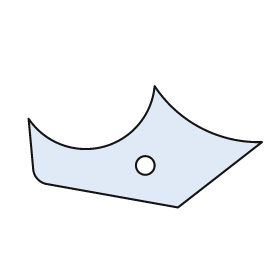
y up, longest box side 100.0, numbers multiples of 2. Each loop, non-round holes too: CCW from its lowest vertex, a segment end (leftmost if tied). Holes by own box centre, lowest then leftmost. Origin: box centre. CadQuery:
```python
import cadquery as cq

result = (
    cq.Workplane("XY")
    .moveTo(14.0, -26.0)
    .lineTo(50.0, 2.0)
    .threePointArc((24.0, 8.0), (4.0, 26.0))
    .threePointArc((-18.0, 0.0), (-50.0, 12.0))
    .lineTo(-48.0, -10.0)
    .threePointArc((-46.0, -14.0), (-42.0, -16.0))
    .close()
    .moveTo(0.0, -8.0)
    .circle(4.0)
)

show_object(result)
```